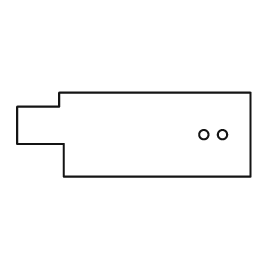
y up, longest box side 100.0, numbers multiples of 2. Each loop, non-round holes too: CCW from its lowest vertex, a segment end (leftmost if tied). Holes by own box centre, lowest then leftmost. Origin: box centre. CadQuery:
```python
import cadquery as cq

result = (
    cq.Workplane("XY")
    .moveTo(-30.0, -18.0)
    .lineTo(50.0, -18.0)
    .lineTo(50.0, 18.0)
    .lineTo(-32.0, 18.0)
    .lineTo(-32.0, 12.0)
    .lineTo(-50.0, 12.0)
    .lineTo(-50.0, -4.0)
    .lineTo(-30.0, -4.0)
    .close()
    .moveTo(30.0, 0.0)
    .circle(2.0)
    .moveTo(38.0, 0.0)
    .circle(2.0)
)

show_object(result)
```